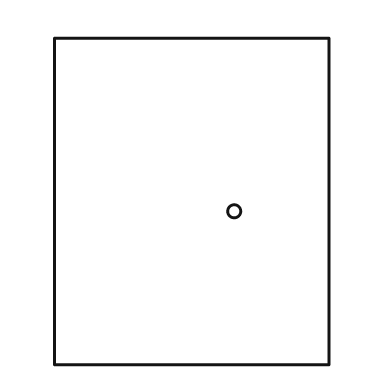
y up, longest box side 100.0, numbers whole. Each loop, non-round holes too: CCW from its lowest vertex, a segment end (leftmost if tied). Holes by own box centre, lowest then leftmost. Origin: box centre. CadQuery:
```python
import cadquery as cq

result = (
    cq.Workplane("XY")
    .moveTo(-42.0, -50.0)
    .lineTo(42.0, -50.0)
    .lineTo(42.0, 50.0)
    .lineTo(-42.0, 50.0)
    .close()
    .moveTo(13.0, -3.0)
    .circle(2.0)
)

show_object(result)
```